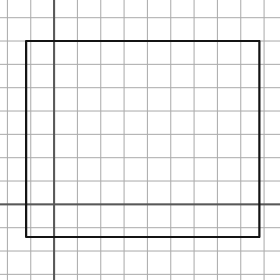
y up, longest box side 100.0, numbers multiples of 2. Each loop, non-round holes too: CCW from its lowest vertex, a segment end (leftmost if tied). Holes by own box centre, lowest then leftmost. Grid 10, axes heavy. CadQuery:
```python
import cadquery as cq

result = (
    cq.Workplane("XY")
    .moveTo(-12.0, -14.0)
    .lineTo(88.0, -14.0)
    .lineTo(88.0, 70.0)
    .lineTo(-12.0, 70.0)
    .close()
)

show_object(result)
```